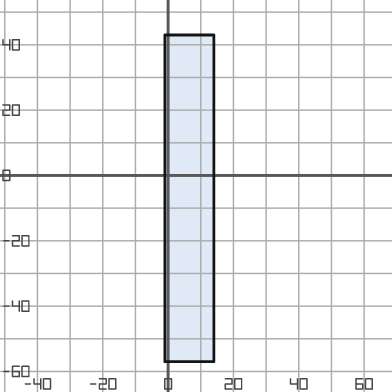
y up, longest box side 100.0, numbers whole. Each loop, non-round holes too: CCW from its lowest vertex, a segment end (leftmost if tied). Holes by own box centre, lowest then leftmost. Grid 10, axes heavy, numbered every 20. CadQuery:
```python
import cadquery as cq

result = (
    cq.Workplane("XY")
    .moveTo(-1.0, -57.0)
    .lineTo(14.0, -57.0)
    .lineTo(14.0, 43.0)
    .lineTo(-1.0, 43.0)
    .close()
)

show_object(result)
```